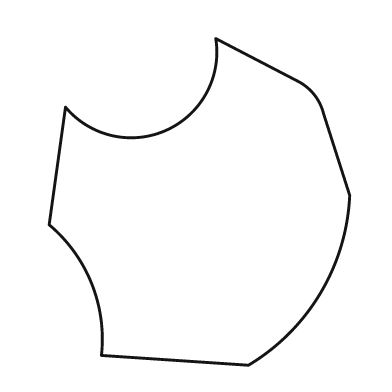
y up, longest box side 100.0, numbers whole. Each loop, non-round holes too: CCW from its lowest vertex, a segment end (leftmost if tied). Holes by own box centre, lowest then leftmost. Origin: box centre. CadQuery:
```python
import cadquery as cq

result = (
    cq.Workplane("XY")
    .moveTo(15.0, -50.0)
    .threePointArc((37.0, -28.0), (46.0, 2.0))
    .lineTo(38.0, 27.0)
    .threePointArc((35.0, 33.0), (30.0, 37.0))
    .lineTo(5.0, 50.0)
    .threePointArc((-10.0, 22.0), (-41.0, 29.0))
    .lineTo(-46.0, -7.0)
    .threePointArc((-33.0, -25.0), (-30.0, -47.0))
    .close()
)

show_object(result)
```